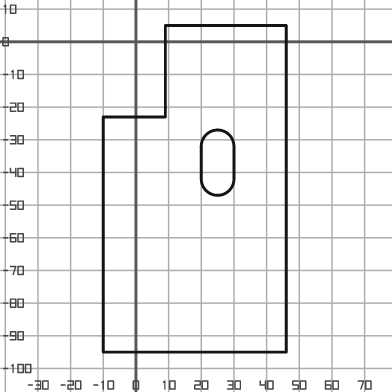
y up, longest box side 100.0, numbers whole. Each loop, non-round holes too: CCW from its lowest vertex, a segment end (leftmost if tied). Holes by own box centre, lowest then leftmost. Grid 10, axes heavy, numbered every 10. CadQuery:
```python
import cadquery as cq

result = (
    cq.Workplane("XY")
    .moveTo(-10.0, -95.0)
    .lineTo(46.0, -95.0)
    .lineTo(46.0, 5.0)
    .lineTo(9.0, 5.0)
    .lineTo(9.0, -23.0)
    .lineTo(-10.0, -23.0)
    .close()
    .moveTo(20.0, -42.0)
    .threePointArc((25.0, -47.0), (30.0, -42.0))
    .lineTo(30.0, -32.0)
    .threePointArc((25.0, -27.0), (20.0, -32.0))
    .close()
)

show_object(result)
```